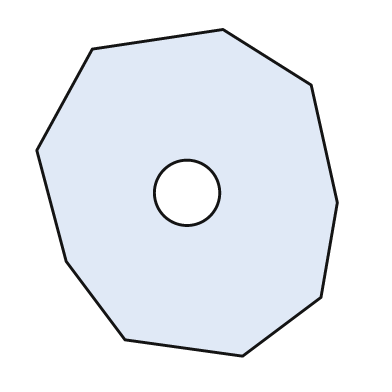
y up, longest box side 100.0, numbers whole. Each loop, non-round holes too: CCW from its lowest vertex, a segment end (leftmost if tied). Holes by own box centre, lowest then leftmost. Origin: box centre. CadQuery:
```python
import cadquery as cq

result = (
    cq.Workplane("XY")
    .moveTo(17.0, -50.0)
    .lineTo(41.0, -32.0)
    .lineTo(46.0, -3.0)
    .lineTo(38.0, 33.0)
    .lineTo(11.0, 50.0)
    .lineTo(-29.0, 44.0)
    .lineTo(-46.0, 13.0)
    .lineTo(-37.0, -21.0)
    .lineTo(-19.0, -45.0)
    .close()
    .moveTo(0.0, 0.0)
    .circle(10.0)
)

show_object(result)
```